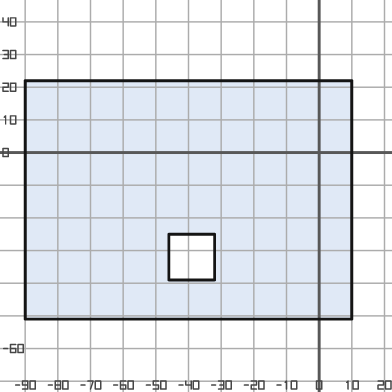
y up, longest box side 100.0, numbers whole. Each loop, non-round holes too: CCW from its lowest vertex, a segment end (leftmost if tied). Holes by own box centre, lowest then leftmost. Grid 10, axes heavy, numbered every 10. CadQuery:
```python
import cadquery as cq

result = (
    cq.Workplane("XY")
    .moveTo(-90.0, -51.0)
    .lineTo(10.0, -51.0)
    .lineTo(10.0, 22.0)
    .lineTo(-90.0, 22.0)
    .close()
    .moveTo(-46.0, -39.0)
    .lineTo(-32.0, -39.0)
    .lineTo(-32.0, -25.0)
    .lineTo(-46.0, -25.0)
    .close()
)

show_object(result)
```